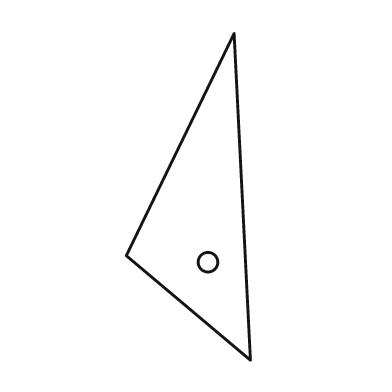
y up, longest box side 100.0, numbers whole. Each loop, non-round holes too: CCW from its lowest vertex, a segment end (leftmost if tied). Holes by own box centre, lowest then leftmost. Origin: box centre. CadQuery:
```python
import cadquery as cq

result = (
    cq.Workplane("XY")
    .moveTo(19.0, -50.0)
    .lineTo(14.0, 50.0)
    .lineTo(-19.0, -18.0)
    .close()
    .moveTo(6.0, -20.0)
    .circle(3.0)
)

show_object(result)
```